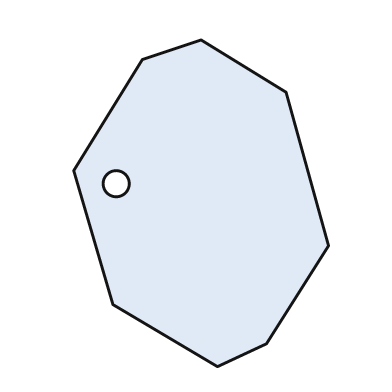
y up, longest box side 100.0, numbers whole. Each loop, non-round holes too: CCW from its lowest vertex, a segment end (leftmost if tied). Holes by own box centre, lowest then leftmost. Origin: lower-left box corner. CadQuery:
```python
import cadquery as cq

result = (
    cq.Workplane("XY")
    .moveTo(44.0, 0.0)
    .lineTo(59.0, 7.0)
    .lineTo(78.0, 37.0)
    .lineTo(65.0, 84.0)
    .lineTo(39.0, 100.0)
    .lineTo(21.0, 94.0)
    .lineTo(0.0, 60.0)
    .lineTo(12.0, 19.0)
    .close()
    .moveTo(13.0, 56.0)
    .circle(4.0)
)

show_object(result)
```